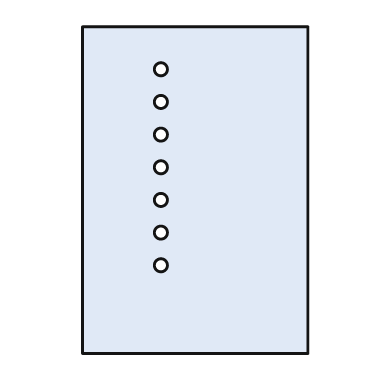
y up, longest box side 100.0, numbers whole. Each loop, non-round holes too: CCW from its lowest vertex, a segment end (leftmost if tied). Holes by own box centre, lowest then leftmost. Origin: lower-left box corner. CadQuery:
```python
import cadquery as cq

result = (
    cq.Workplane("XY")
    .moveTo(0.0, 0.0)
    .lineTo(69.0, 0.0)
    .lineTo(69.0, 100.0)
    .lineTo(0.0, 100.0)
    .close()
    .moveTo(24.0, 27.0)
    .circle(2.0)
    .moveTo(24.0, 37.0)
    .circle(2.0)
    .moveTo(24.0, 47.0)
    .circle(2.0)
    .moveTo(24.0, 57.0)
    .circle(2.0)
    .moveTo(24.0, 67.0)
    .circle(2.0)
    .moveTo(24.0, 77.0)
    .circle(2.0)
    .moveTo(24.0, 87.0)
    .circle(2.0)
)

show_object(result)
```